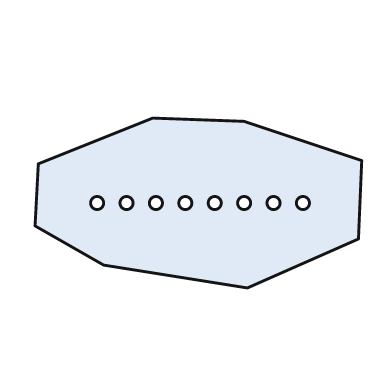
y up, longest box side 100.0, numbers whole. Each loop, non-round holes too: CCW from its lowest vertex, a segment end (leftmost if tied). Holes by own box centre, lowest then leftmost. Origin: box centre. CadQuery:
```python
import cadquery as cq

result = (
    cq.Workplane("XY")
    .moveTo(15.0, -26.0)
    .lineTo(49.0, -11.0)
    .lineTo(50.0, 13.0)
    .lineTo(14.0, 25.0)
    .lineTo(-14.0, 26.0)
    .lineTo(-49.0, 12.0)
    .lineTo(-50.0, -7.0)
    .lineTo(-29.0, -19.0)
    .close()
    .moveTo(-31.0, 0.0)
    .circle(2.0)
    .moveTo(-22.0, 0.0)
    .circle(2.0)
    .moveTo(-13.0, 0.0)
    .circle(2.0)
    .moveTo(-4.0, 0.0)
    .circle(2.0)
    .moveTo(5.0, 0.0)
    .circle(2.0)
    .moveTo(14.0, 0.0)
    .circle(2.0)
    .moveTo(23.0, 0.0)
    .circle(2.0)
    .moveTo(32.0, 0.0)
    .circle(2.0)
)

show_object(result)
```